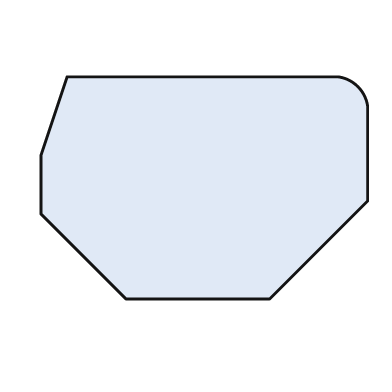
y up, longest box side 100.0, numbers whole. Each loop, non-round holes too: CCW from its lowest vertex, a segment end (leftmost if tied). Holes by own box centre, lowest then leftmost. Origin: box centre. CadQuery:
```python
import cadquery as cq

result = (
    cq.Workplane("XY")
    .moveTo(-24.0, -34.0)
    .lineTo(20.0, -34.0)
    .lineTo(50.0, -4.0)
    .lineTo(50.0, 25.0)
    .threePointArc((47.0, 31.0), (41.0, 34.0))
    .lineTo(-42.0, 34.0)
    .lineTo(-50.0, 10.0)
    .lineTo(-50.0, -8.0)
    .close()
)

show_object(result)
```